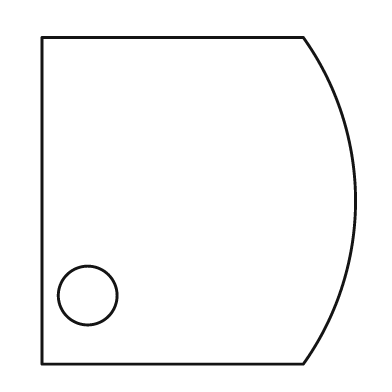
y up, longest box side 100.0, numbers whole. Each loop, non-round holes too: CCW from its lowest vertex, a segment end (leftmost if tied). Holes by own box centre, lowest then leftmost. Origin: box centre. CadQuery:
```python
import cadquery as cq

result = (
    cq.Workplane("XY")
    .moveTo(-48.0, -50.0)
    .lineTo(32.0, -50.0)
    .threePointArc((48.0, 0.0), (32.0, 50.0))
    .lineTo(-48.0, 50.0)
    .close()
    .moveTo(-34.0, -29.0)
    .circle(9.0)
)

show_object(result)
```